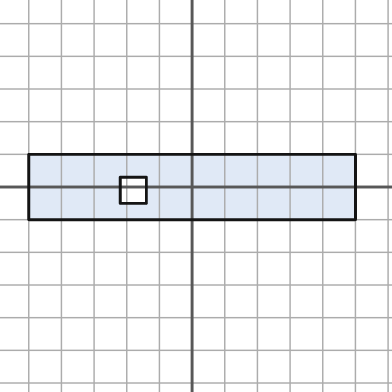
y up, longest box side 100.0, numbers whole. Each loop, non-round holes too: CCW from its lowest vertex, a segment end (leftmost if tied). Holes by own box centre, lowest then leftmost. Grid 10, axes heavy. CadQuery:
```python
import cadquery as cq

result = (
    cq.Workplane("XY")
    .moveTo(-50.0, -10.0)
    .lineTo(50.0, -10.0)
    .lineTo(50.0, 10.0)
    .lineTo(-50.0, 10.0)
    .close()
    .moveTo(-22.0, -5.0)
    .lineTo(-14.0, -5.0)
    .lineTo(-14.0, 3.0)
    .lineTo(-22.0, 3.0)
    .close()
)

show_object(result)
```